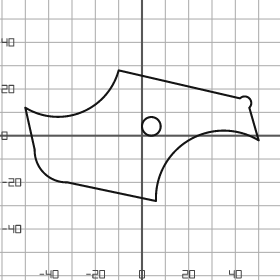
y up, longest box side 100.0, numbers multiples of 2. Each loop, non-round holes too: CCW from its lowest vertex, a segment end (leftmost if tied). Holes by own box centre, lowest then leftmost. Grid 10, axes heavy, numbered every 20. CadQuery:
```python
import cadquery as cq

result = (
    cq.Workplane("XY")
    .moveTo(6.0, -28.0)
    .threePointArc((20.0, -2.0), (50.0, -2.0))
    .lineTo(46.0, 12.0)
    .threePointArc((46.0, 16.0), (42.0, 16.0))
    .lineTo(-10.0, 28.0)
    .threePointArc((-26.0, 10.0), (-50.0, 12.0))
    .lineTo(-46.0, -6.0)
    .threePointArc((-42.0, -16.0), (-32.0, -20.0))
    .close()
    .moveTo(4.0, 4.0)
    .circle(4.0)
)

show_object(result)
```